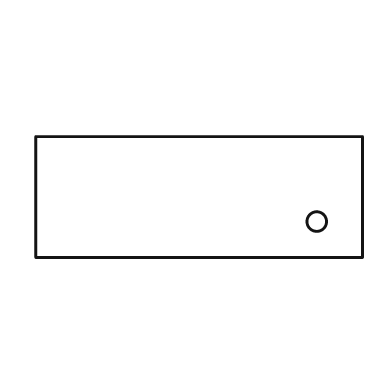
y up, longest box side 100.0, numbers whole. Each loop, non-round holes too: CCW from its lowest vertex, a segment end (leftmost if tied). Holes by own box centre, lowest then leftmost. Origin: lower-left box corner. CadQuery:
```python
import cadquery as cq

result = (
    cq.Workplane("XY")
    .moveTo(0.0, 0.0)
    .lineTo(100.0, 0.0)
    .lineTo(100.0, 37.0)
    .lineTo(0.0, 37.0)
    .close()
    .moveTo(86.0, 11.0)
    .circle(3.0)
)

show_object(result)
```